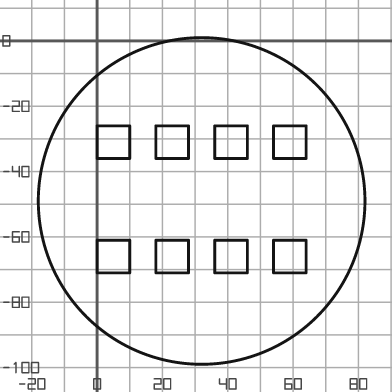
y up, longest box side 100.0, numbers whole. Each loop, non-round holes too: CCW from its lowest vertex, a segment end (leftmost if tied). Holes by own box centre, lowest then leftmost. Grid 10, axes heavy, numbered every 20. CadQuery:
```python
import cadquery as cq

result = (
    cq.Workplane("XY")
    .moveTo(32.0, -49.0)
    .circle(50.0)
    .moveTo(0.0, -71.0)
    .lineTo(10.0, -71.0)
    .lineTo(10.0, -61.0)
    .lineTo(0.0, -61.0)
    .close()
    .moveTo(18.0, -71.0)
    .lineTo(28.0, -71.0)
    .lineTo(28.0, -61.0)
    .lineTo(18.0, -61.0)
    .close()
    .moveTo(36.0, -71.0)
    .lineTo(46.0, -71.0)
    .lineTo(46.0, -61.0)
    .lineTo(36.0, -61.0)
    .close()
    .moveTo(54.0, -71.0)
    .lineTo(64.0, -71.0)
    .lineTo(64.0, -61.0)
    .lineTo(54.0, -61.0)
    .close()
    .moveTo(0.0, -36.0)
    .lineTo(10.0, -36.0)
    .lineTo(10.0, -26.0)
    .lineTo(0.0, -26.0)
    .close()
    .moveTo(18.0, -36.0)
    .lineTo(28.0, -36.0)
    .lineTo(28.0, -26.0)
    .lineTo(18.0, -26.0)
    .close()
    .moveTo(36.0, -36.0)
    .lineTo(46.0, -36.0)
    .lineTo(46.0, -26.0)
    .lineTo(36.0, -26.0)
    .close()
    .moveTo(54.0, -36.0)
    .lineTo(64.0, -36.0)
    .lineTo(64.0, -26.0)
    .lineTo(54.0, -26.0)
    .close()
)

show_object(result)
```